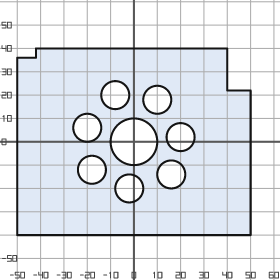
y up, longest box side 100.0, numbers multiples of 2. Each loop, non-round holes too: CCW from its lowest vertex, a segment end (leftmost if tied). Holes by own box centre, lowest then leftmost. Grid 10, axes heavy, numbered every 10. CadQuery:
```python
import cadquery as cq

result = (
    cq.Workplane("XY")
    .moveTo(-50.0, -40.0)
    .lineTo(50.0, -40.0)
    .lineTo(50.0, 22.0)
    .lineTo(40.0, 22.0)
    .lineTo(40.0, 40.0)
    .lineTo(-42.0, 40.0)
    .lineTo(-42.0, 36.0)
    .lineTo(-50.0, 36.0)
    .close()
    .moveTo(-2.0, -20.0)
    .circle(6.0)
    .moveTo(16.0, -14.0)
    .circle(6.0)
    .moveTo(-18.0, -12.0)
    .circle(6.0)
    .moveTo(0.0, 0.0)
    .circle(10.0)
    .moveTo(20.0, 2.0)
    .circle(6.0)
    .moveTo(-20.0, 6.0)
    .circle(6.0)
    .moveTo(10.0, 18.0)
    .circle(6.0)
    .moveTo(-8.0, 20.0)
    .circle(6.0)
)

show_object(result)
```